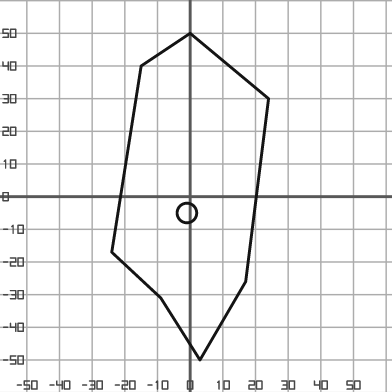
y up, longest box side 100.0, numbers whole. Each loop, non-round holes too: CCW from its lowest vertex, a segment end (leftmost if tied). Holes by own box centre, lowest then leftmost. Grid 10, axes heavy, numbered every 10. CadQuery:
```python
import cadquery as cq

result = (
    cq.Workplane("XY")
    .moveTo(3.0, -50.0)
    .lineTo(17.0, -26.0)
    .lineTo(24.0, 30.0)
    .lineTo(0.0, 50.0)
    .lineTo(-15.0, 40.0)
    .lineTo(-24.0, -17.0)
    .lineTo(-9.0, -31.0)
    .close()
    .moveTo(-1.0, -5.0)
    .circle(3.0)
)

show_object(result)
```